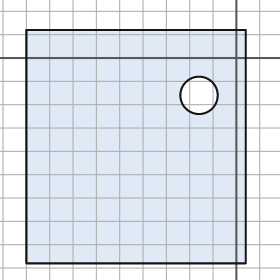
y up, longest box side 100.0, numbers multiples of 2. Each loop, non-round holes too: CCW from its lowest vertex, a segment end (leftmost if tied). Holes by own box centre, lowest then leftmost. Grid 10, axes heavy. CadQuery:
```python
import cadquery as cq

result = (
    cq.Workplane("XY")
    .moveTo(-90.0, -88.0)
    .lineTo(4.0, -88.0)
    .lineTo(4.0, 12.0)
    .lineTo(-90.0, 12.0)
    .close()
    .moveTo(-16.0, -16.0)
    .circle(8.0)
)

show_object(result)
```